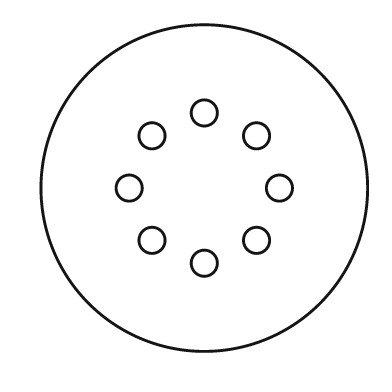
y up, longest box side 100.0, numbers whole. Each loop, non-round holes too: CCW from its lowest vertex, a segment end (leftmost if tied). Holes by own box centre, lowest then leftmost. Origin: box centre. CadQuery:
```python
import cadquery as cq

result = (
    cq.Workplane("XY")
    .moveTo(0.0, 0.0)
    .circle(50.0)
    .moveTo(0.0, -23.0)
    .circle(4.0)
    .moveTo(-16.0, -16.0)
    .circle(4.0)
    .moveTo(16.0, -16.0)
    .circle(4.0)
    .moveTo(-23.0, 0.0)
    .circle(4.0)
    .moveTo(23.0, 0.0)
    .circle(4.0)
    .moveTo(-16.0, 16.0)
    .circle(4.0)
    .moveTo(16.0, 16.0)
    .circle(4.0)
    .moveTo(0.0, 23.0)
    .circle(4.0)
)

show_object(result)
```